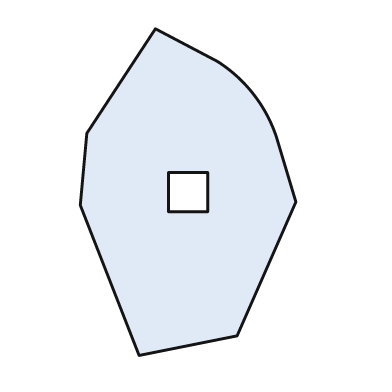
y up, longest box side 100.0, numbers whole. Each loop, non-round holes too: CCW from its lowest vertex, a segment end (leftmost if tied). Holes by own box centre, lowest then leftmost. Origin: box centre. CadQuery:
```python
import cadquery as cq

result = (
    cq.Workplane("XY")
    .moveTo(-15.0, -50.0)
    .lineTo(15.0, -44.0)
    .lineTo(33.0, -3.0)
    .lineTo(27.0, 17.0)
    .threePointArc((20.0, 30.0), (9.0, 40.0))
    .lineTo(-10.0, 50.0)
    .lineTo(-31.0, 18.0)
    .lineTo(-33.0, -4.0)
    .close()
    .moveTo(-6.0, -6.0)
    .lineTo(6.0, -6.0)
    .lineTo(6.0, 6.0)
    .lineTo(-6.0, 6.0)
    .close()
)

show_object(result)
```